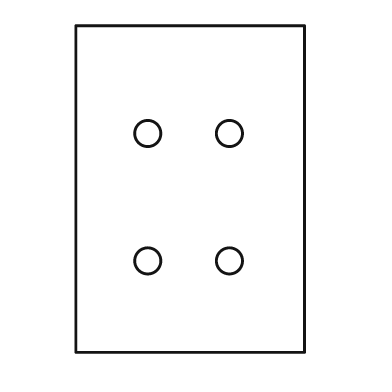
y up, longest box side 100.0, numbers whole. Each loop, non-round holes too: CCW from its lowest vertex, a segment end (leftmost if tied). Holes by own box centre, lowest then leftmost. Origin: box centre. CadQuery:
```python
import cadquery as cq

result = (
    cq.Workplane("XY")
    .moveTo(-35.0, -50.0)
    .lineTo(35.0, -50.0)
    .lineTo(35.0, 50.0)
    .lineTo(-35.0, 50.0)
    .close()
    .moveTo(-13.0, -22.0)
    .circle(4.0)
    .moveTo(12.0, -22.0)
    .circle(4.0)
    .moveTo(-13.0, 17.0)
    .circle(4.0)
    .moveTo(12.0, 17.0)
    .circle(4.0)
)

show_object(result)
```